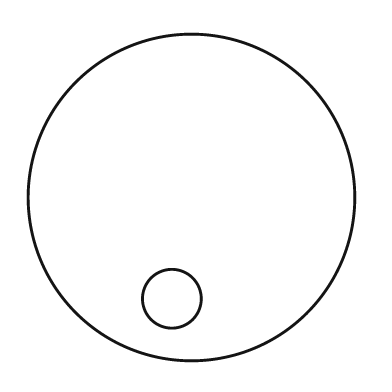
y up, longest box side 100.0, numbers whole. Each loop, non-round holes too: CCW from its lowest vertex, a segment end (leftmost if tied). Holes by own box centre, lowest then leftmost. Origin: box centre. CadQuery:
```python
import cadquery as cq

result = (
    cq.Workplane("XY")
    .moveTo(0.0, 0.0)
    .circle(50.0)
    .moveTo(-6.0, -31.0)
    .circle(9.0)
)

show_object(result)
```